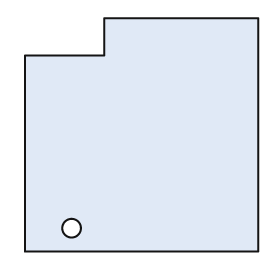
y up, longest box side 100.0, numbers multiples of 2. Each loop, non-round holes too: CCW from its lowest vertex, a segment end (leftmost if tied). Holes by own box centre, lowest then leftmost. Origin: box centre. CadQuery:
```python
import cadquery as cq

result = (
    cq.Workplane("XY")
    .moveTo(-50.0, -50.0)
    .lineTo(50.0, -50.0)
    .lineTo(50.0, 50.0)
    .lineTo(-16.0, 50.0)
    .lineTo(-16.0, 34.0)
    .lineTo(-50.0, 34.0)
    .close()
    .moveTo(-30.0, -40.0)
    .circle(4.0)
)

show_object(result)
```